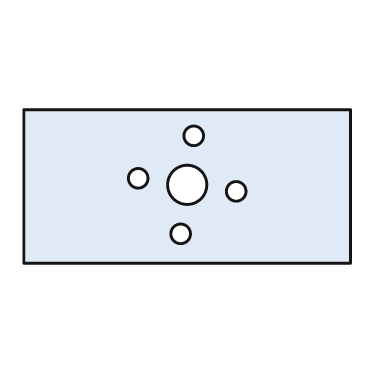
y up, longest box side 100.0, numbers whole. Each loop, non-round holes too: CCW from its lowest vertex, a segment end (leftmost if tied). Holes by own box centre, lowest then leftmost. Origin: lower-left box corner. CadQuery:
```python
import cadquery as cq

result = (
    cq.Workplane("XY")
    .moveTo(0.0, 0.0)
    .lineTo(100.0, 0.0)
    .lineTo(100.0, 47.0)
    .lineTo(0.0, 47.0)
    .close()
    .moveTo(48.0, 9.0)
    .circle(3.0)
    .moveTo(65.0, 22.0)
    .circle(3.0)
    .moveTo(50.0, 24.0)
    .circle(6.0)
    .moveTo(35.0, 26.0)
    .circle(3.0)
    .moveTo(52.0, 39.0)
    .circle(3.0)
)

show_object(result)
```